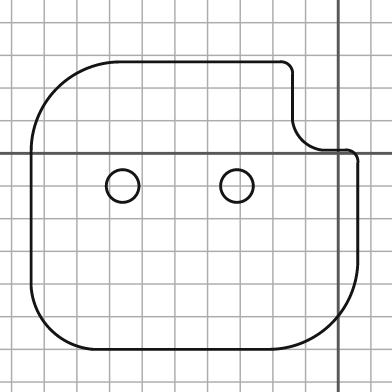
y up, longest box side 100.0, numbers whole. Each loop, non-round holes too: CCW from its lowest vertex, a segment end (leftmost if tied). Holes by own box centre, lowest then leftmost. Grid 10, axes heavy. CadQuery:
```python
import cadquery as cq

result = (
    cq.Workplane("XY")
    .moveTo(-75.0, -60.0)
    .lineTo(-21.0, -60.0)
    .threePointArc((-2.0, -52.0), (6.0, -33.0))
    .lineTo(6.0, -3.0)
    .threePointArc((5.0, 0.0), (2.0, 1.0))
    .lineTo(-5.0, 1.0)
    .threePointArc((-11.0, 4.0), (-14.0, 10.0))
    .lineTo(-14.0, 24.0)
    .threePointArc((-15.0, 27.0), (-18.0, 28.0))
    .lineTo(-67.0, 28.0)
    .threePointArc((-86.0, 20.0), (-94.0, 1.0))
    .lineTo(-94.0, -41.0)
    .threePointArc((-88.0, -54.0), (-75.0, -60.0))
    .close()
    .moveTo(-66.0, -10.0)
    .circle(5.0)
    .moveTo(-31.0, -10.0)
    .circle(5.0)
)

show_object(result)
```